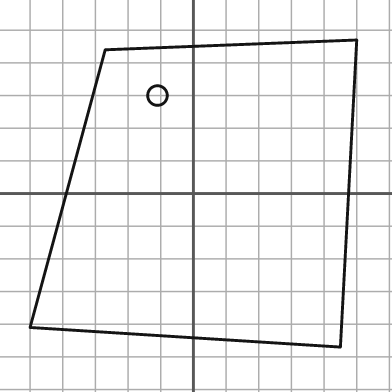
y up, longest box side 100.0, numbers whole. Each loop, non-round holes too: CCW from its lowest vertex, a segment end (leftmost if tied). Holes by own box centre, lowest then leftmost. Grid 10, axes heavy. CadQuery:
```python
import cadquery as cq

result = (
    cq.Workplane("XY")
    .moveTo(45.0, -47.0)
    .lineTo(50.0, 47.0)
    .lineTo(-27.0, 44.0)
    .lineTo(-50.0, -41.0)
    .close()
    .moveTo(-11.0, 30.0)
    .circle(3.0)
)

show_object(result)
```